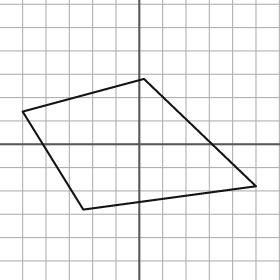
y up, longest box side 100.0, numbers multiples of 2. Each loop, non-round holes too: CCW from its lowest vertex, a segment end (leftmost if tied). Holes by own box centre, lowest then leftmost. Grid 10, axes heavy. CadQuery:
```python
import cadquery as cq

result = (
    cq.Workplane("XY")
    .moveTo(-24.0, -28.0)
    .lineTo(50.0, -18.0)
    .lineTo(2.0, 28.0)
    .lineTo(-50.0, 14.0)
    .close()
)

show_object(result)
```